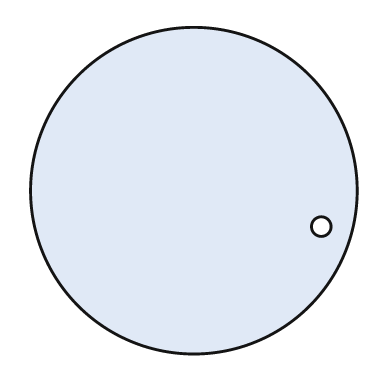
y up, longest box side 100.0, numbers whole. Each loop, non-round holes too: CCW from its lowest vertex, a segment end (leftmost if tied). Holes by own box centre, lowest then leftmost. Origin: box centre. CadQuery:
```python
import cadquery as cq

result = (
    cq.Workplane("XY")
    .moveTo(0.0, 0.0)
    .circle(50.0)
    .moveTo(39.0, -11.0)
    .circle(3.0)
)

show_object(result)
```